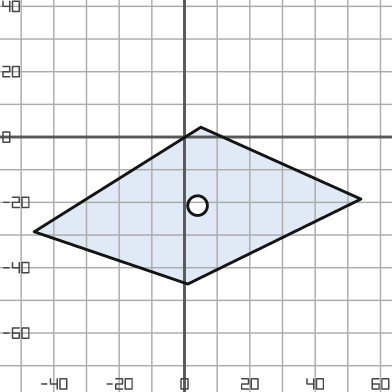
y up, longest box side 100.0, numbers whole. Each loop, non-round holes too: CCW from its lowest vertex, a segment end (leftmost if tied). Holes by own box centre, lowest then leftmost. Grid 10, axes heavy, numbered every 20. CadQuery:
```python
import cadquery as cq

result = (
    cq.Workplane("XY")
    .moveTo(1.0, -45.0)
    .lineTo(54.0, -19.0)
    .lineTo(5.0, 3.0)
    .lineTo(-46.0, -29.0)
    .close()
    .moveTo(4.0, -21.0)
    .circle(3.0)
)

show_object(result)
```